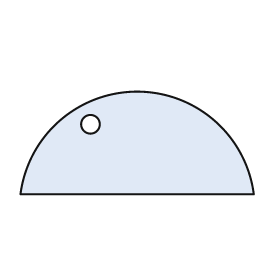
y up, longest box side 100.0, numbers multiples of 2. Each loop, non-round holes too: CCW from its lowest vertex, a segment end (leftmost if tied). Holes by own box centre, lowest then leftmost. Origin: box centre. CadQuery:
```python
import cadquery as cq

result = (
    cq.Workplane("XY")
    .moveTo(-50.0, -22.0)
    .lineTo(50.0, -22.0)
    .threePointArc((0.0, 22.0), (-50.0, -22.0))
    .close()
    .moveTo(-20.0, 8.0)
    .circle(4.0)
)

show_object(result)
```